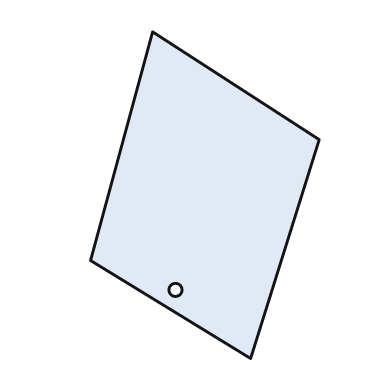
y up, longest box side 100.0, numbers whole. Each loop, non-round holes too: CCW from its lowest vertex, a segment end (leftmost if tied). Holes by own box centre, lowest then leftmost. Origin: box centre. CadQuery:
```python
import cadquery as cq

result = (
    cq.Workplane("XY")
    .moveTo(14.0, -50.0)
    .lineTo(35.0, 17.0)
    .lineTo(-16.0, 50.0)
    .lineTo(-35.0, -20.0)
    .close()
    .moveTo(-9.0, -29.0)
    .circle(2.0)
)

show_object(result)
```